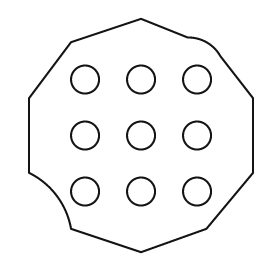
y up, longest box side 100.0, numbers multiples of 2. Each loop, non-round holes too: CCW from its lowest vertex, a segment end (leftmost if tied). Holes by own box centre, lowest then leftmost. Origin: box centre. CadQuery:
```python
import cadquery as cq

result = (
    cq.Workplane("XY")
    .moveTo(0.0, -50.0)
    .lineTo(28.0, -40.0)
    .lineTo(48.0, -16.0)
    .lineTo(48.0, 16.0)
    .lineTo(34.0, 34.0)
    .threePointArc((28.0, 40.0), (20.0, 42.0))
    .lineTo(0.0, 50.0)
    .lineTo(-30.0, 40.0)
    .lineTo(-48.0, 16.0)
    .lineTo(-48.0, -16.0)
    .threePointArc((-36.0, -26.0), (-30.0, -40.0))
    .close()
    .moveTo(-24.0, -24.0)
    .circle(6.0)
    .moveTo(0.0, -24.0)
    .circle(6.0)
    .moveTo(24.0, -24.0)
    .circle(6.0)
    .moveTo(-24.0, 0.0)
    .circle(6.0)
    .moveTo(0.0, 0.0)
    .circle(6.0)
    .moveTo(24.0, 0.0)
    .circle(6.0)
    .moveTo(-24.0, 24.0)
    .circle(6.0)
    .moveTo(0.0, 24.0)
    .circle(6.0)
    .moveTo(24.0, 24.0)
    .circle(6.0)
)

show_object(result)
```